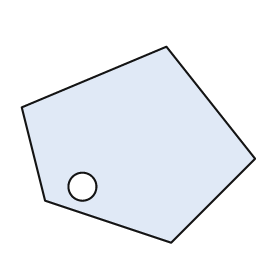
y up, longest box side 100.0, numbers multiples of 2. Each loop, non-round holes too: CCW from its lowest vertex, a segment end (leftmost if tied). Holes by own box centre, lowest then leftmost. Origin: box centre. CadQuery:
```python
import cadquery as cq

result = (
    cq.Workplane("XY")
    .moveTo(14.0, -42.0)
    .lineTo(50.0, -6.0)
    .lineTo(12.0, 42.0)
    .lineTo(-50.0, 16.0)
    .lineTo(-40.0, -24.0)
    .close()
    .moveTo(-24.0, -18.0)
    .circle(6.0)
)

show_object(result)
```